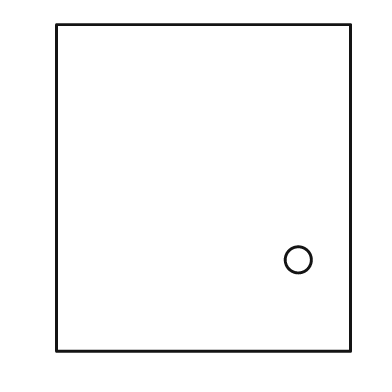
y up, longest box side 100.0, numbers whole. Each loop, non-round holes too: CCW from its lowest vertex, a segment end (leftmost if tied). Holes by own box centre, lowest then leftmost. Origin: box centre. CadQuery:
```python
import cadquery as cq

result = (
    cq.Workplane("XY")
    .moveTo(-45.0, -50.0)
    .lineTo(45.0, -50.0)
    .lineTo(45.0, 50.0)
    .lineTo(-45.0, 50.0)
    .close()
    .moveTo(29.0, -22.0)
    .circle(4.0)
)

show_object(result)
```